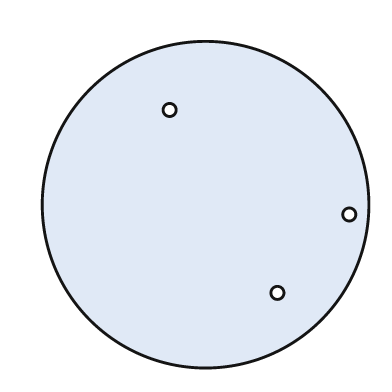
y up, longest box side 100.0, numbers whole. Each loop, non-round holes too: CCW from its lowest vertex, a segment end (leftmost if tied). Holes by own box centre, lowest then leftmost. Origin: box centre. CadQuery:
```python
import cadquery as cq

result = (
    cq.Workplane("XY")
    .moveTo(0.0, 0.0)
    .circle(50.0)
    .moveTo(22.0, -27.0)
    .circle(2.0)
    .moveTo(44.0, -3.0)
    .circle(2.0)
    .moveTo(-11.0, 29.0)
    .circle(2.0)
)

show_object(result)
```